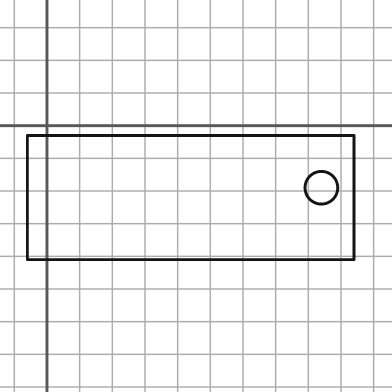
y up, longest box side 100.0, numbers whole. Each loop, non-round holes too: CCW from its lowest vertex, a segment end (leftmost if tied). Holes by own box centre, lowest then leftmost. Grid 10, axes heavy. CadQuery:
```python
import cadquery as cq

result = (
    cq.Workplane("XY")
    .moveTo(-6.0, -41.0)
    .lineTo(94.0, -41.0)
    .lineTo(94.0, -3.0)
    .lineTo(-6.0, -3.0)
    .close()
    .moveTo(84.0, -19.0)
    .circle(5.0)
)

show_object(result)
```